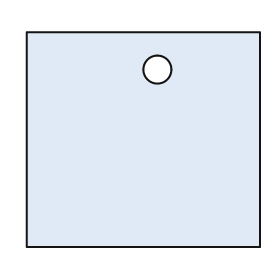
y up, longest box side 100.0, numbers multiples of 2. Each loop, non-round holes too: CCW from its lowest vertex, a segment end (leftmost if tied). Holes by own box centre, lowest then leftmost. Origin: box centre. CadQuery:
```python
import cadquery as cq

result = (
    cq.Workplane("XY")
    .moveTo(-50.0, -46.0)
    .lineTo(50.0, -46.0)
    .lineTo(50.0, 46.0)
    .lineTo(-50.0, 46.0)
    .close()
    .moveTo(6.0, 30.0)
    .circle(6.0)
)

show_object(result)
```